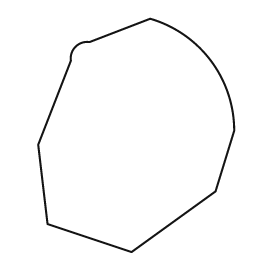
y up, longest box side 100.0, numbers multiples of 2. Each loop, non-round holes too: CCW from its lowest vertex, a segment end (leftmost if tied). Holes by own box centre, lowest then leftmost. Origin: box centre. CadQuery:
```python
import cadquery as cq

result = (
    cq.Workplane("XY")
    .moveTo(-2.0, -50.0)
    .lineTo(34.0, -24.0)
    .lineTo(42.0, 2.0)
    .threePointArc((32.0, 32.0), (6.0, 50.0))
    .lineTo(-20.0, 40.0)
    .threePointArc((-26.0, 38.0), (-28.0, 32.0))
    .lineTo(-42.0, -4.0)
    .lineTo(-38.0, -38.0)
    .close()
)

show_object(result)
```